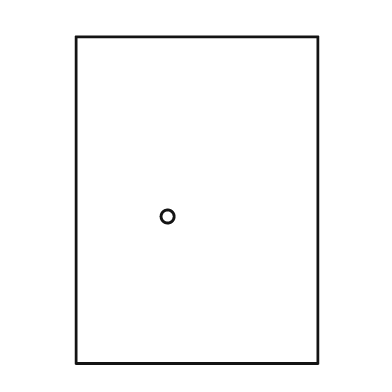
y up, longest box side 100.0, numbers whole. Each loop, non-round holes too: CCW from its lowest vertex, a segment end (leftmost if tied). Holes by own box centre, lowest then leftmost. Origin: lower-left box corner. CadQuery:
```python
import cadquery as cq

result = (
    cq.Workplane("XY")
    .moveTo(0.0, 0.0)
    .lineTo(74.0, 0.0)
    .lineTo(74.0, 100.0)
    .lineTo(0.0, 100.0)
    .close()
    .moveTo(28.0, 45.0)
    .circle(2.0)
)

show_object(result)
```